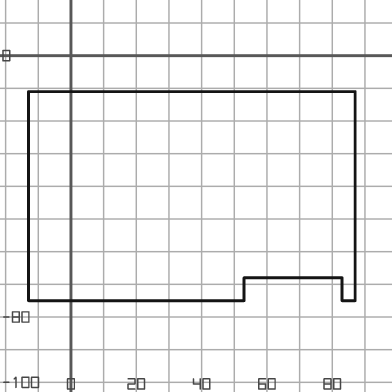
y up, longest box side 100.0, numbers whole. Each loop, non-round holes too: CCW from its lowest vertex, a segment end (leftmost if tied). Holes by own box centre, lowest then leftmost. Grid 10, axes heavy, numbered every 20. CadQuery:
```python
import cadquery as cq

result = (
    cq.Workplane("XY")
    .moveTo(-13.0, -75.0)
    .lineTo(53.0, -75.0)
    .lineTo(53.0, -68.0)
    .lineTo(83.0, -68.0)
    .lineTo(83.0, -75.0)
    .lineTo(87.0, -75.0)
    .lineTo(87.0, -11.0)
    .lineTo(-13.0, -11.0)
    .close()
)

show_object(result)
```